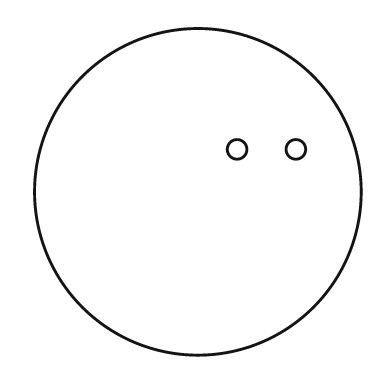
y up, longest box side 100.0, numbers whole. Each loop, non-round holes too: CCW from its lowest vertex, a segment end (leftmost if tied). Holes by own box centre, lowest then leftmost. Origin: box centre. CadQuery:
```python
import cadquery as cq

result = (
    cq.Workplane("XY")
    .moveTo(0.0, 0.0)
    .circle(50.0)
    .moveTo(12.0, 13.0)
    .circle(3.0)
    .moveTo(30.0, 13.0)
    .circle(3.0)
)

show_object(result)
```